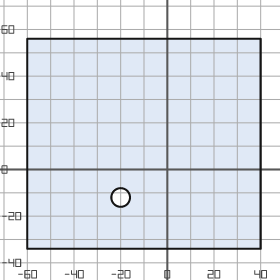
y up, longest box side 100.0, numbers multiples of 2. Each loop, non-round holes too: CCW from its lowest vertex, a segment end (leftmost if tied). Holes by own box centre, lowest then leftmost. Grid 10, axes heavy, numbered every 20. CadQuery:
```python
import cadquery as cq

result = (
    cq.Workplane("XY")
    .moveTo(-60.0, -34.0)
    .lineTo(40.0, -34.0)
    .lineTo(40.0, 56.0)
    .lineTo(-60.0, 56.0)
    .close()
    .moveTo(-20.0, -12.0)
    .circle(4.0)
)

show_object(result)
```